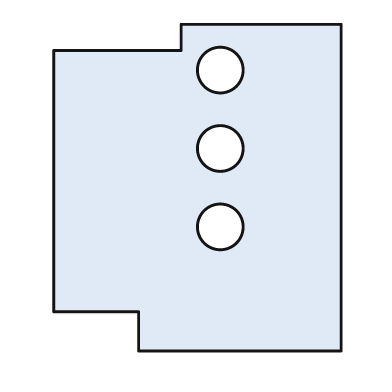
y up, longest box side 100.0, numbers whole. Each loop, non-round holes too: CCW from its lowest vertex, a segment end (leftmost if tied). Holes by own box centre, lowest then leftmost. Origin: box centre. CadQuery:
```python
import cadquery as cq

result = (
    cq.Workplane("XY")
    .moveTo(-18.0, -50.0)
    .lineTo(44.0, -50.0)
    .lineTo(44.0, 50.0)
    .lineTo(-5.0, 50.0)
    .lineTo(-5.0, 42.0)
    .lineTo(-44.0, 42.0)
    .lineTo(-44.0, -38.0)
    .lineTo(-18.0, -38.0)
    .close()
    .moveTo(7.0, -12.0)
    .circle(7.0)
    .moveTo(7.0, 12.0)
    .circle(7.0)
    .moveTo(7.0, 36.0)
    .circle(7.0)
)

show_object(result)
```